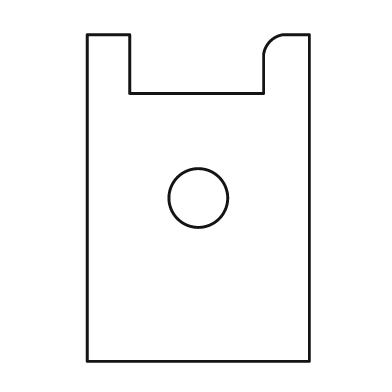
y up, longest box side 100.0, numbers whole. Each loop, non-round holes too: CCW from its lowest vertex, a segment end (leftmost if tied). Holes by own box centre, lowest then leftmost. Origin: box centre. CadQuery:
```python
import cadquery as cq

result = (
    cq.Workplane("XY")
    .moveTo(-34.0, -50.0)
    .lineTo(34.0, -50.0)
    .lineTo(34.0, 50.0)
    .lineTo(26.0, 50.0)
    .threePointArc((22.0, 48.0), (20.0, 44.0))
    .lineTo(20.0, 32.0)
    .lineTo(-21.0, 32.0)
    .lineTo(-21.0, 50.0)
    .lineTo(-34.0, 50.0)
    .close()
    .moveTo(0.0, 0.0)
    .circle(9.0)
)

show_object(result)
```